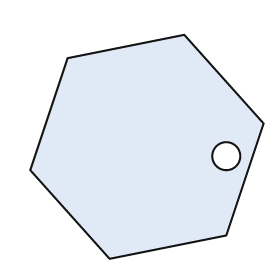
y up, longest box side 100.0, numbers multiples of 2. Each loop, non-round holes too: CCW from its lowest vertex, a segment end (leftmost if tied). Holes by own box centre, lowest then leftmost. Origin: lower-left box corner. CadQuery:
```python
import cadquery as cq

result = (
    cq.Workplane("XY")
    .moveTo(34.0, 0.0)
    .lineTo(84.0, 10.0)
    .lineTo(100.0, 58.0)
    .lineTo(66.0, 96.0)
    .lineTo(16.0, 86.0)
    .lineTo(0.0, 38.0)
    .close()
    .moveTo(84.0, 44.0)
    .circle(6.0)
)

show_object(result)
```